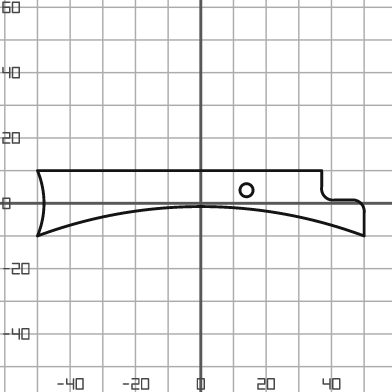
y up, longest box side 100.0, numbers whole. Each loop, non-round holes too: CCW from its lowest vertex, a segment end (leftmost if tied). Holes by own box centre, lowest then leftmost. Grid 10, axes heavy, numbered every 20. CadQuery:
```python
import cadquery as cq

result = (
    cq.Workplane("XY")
    .moveTo(-50.0, -10.0)
    .threePointArc((0.0, -1.0), (50.0, -10.0))
    .lineTo(50.0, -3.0)
    .threePointArc((49.0, 0.0), (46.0, 1.0))
    .lineTo(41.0, 1.0)
    .threePointArc((38.0, 2.0), (37.0, 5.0))
    .lineTo(37.0, 10.0)
    .lineTo(-50.0, 10.0)
    .threePointArc((-48.0, 0.0), (-50.0, -10.0))
    .close()
    .moveTo(14.0, 4.0)
    .circle(2.0)
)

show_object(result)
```